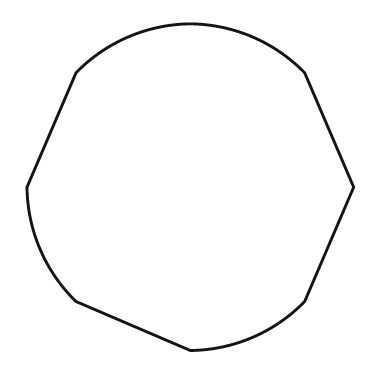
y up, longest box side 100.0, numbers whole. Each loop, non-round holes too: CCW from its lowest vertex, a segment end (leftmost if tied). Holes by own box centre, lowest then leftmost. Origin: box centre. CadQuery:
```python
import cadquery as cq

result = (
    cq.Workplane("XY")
    .moveTo(0.0, -50.0)
    .threePointArc((19.0, -46.0), (35.0, -35.0))
    .lineTo(50.0, 0.0)
    .lineTo(35.0, 35.0)
    .threePointArc((19.0, 46.0), (0.0, 50.0))
    .threePointArc((-19.0, 46.0), (-35.0, 35.0))
    .lineTo(-50.0, 0.0)
    .threePointArc((-46.0, -19.0), (-35.0, -35.0))
    .close()
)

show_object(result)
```